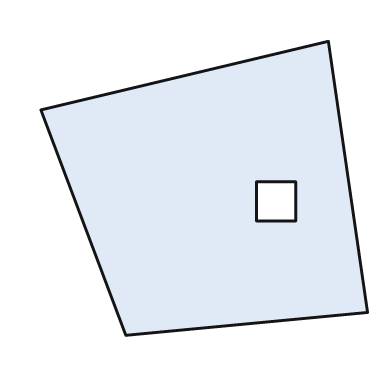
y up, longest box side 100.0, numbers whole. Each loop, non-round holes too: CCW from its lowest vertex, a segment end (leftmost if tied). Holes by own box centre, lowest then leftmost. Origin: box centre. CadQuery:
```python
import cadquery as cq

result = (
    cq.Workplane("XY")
    .moveTo(-24.0, -45.0)
    .lineTo(50.0, -38.0)
    .lineTo(38.0, 45.0)
    .lineTo(-50.0, 24.0)
    .close()
    .moveTo(16.0, -10.0)
    .lineTo(28.0, -10.0)
    .lineTo(28.0, 2.0)
    .lineTo(16.0, 2.0)
    .close()
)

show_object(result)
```